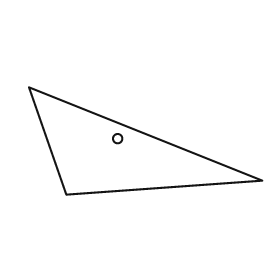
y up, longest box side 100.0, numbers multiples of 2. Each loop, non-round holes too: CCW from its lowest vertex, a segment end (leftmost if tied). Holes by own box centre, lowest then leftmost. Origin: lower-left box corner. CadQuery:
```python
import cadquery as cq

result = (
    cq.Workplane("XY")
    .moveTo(16.0, 0.0)
    .lineTo(100.0, 6.0)
    .lineTo(0.0, 46.0)
    .close()
    .moveTo(38.0, 24.0)
    .circle(2.0)
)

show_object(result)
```